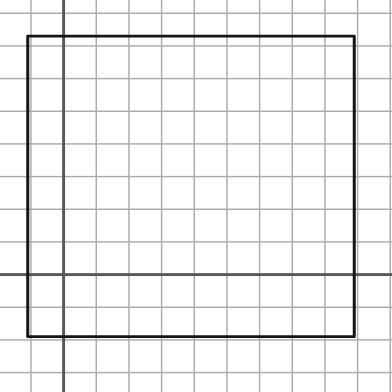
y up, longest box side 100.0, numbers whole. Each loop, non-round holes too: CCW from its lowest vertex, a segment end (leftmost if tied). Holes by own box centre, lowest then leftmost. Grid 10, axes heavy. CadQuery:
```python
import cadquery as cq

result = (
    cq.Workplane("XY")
    .moveTo(-11.0, -19.0)
    .lineTo(89.0, -19.0)
    .lineTo(89.0, 73.0)
    .lineTo(-11.0, 73.0)
    .close()
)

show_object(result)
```